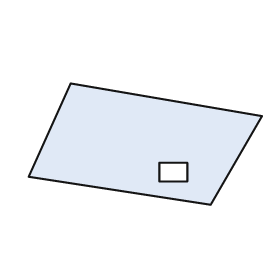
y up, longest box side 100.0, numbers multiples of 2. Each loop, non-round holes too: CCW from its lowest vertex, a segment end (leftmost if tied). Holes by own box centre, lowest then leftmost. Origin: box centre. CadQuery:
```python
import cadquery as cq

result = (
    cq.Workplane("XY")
    .moveTo(28.0, -26.0)
    .lineTo(50.0, 12.0)
    .lineTo(-32.0, 26.0)
    .lineTo(-50.0, -14.0)
    .close()
    .moveTo(6.0, -16.0)
    .lineTo(18.0, -16.0)
    .lineTo(18.0, -8.0)
    .lineTo(6.0, -8.0)
    .close()
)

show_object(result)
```